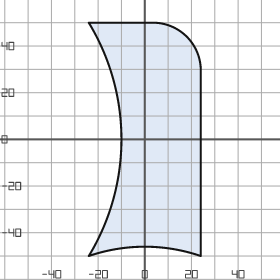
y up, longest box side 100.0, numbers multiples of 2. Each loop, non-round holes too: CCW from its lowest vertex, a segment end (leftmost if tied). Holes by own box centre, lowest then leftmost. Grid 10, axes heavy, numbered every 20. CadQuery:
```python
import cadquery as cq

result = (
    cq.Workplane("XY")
    .moveTo(-24.0, -50.0)
    .threePointArc((0.0, -46.0), (24.0, -50.0))
    .lineTo(24.0, 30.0)
    .threePointArc((18.0, 44.0), (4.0, 50.0))
    .lineTo(-24.0, 50.0)
    .threePointArc((-10.0, 0.0), (-24.0, -50.0))
    .close()
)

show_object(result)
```